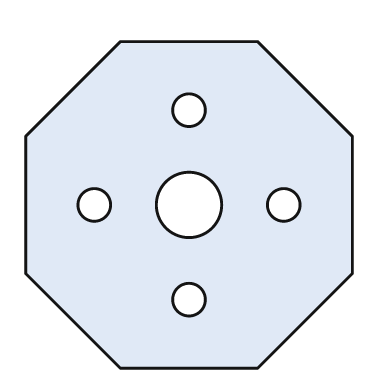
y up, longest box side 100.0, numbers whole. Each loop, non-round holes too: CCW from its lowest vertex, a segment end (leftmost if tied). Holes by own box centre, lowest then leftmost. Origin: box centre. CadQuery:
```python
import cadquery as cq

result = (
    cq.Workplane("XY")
    .moveTo(-21.0, -50.0)
    .lineTo(21.0, -50.0)
    .lineTo(50.0, -21.0)
    .lineTo(50.0, 21.0)
    .lineTo(21.0, 50.0)
    .lineTo(-21.0, 50.0)
    .lineTo(-50.0, 21.0)
    .lineTo(-50.0, -21.0)
    .close()
    .moveTo(0.0, -29.0)
    .circle(5.0)
    .moveTo(-29.0, 0.0)
    .circle(5.0)
    .moveTo(0.0, 0.0)
    .circle(10.0)
    .moveTo(29.0, 0.0)
    .circle(5.0)
    .moveTo(0.0, 29.0)
    .circle(5.0)
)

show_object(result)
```